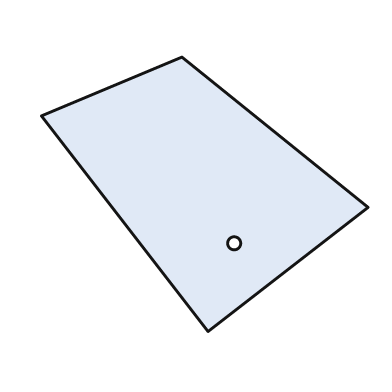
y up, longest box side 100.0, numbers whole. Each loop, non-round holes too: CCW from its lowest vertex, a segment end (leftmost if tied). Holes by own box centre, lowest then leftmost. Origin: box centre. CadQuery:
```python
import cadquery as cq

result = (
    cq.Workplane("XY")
    .moveTo(1.0, -42.0)
    .lineTo(50.0, -4.0)
    .lineTo(-7.0, 42.0)
    .lineTo(-50.0, 24.0)
    .close()
    .moveTo(9.0, -15.0)
    .circle(2.0)
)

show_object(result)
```